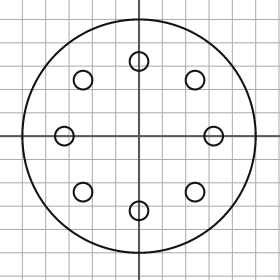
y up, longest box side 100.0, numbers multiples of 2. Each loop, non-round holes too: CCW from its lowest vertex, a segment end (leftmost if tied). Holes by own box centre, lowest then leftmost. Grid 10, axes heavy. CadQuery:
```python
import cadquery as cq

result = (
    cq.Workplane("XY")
    .moveTo(0.0, 0.0)
    .circle(50.0)
    .moveTo(0.0, -32.0)
    .circle(4.0)
    .moveTo(-24.0, -24.0)
    .circle(4.0)
    .moveTo(24.0, -24.0)
    .circle(4.0)
    .moveTo(-32.0, 0.0)
    .circle(4.0)
    .moveTo(32.0, 0.0)
    .circle(4.0)
    .moveTo(-24.0, 24.0)
    .circle(4.0)
    .moveTo(24.0, 24.0)
    .circle(4.0)
    .moveTo(0.0, 32.0)
    .circle(4.0)
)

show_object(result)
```